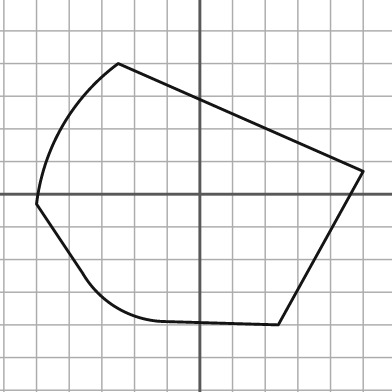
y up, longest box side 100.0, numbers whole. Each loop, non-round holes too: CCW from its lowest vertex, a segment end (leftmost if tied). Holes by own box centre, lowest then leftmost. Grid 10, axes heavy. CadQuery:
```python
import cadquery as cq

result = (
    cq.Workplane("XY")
    .moveTo(24.0, -40.0)
    .lineTo(50.0, 7.0)
    .lineTo(-25.0, 40.0)
    .threePointArc((-42.0, 21.0), (-50.0, -3.0))
    .lineTo(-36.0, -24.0)
    .threePointArc((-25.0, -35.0), (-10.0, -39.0))
    .close()
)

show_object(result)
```